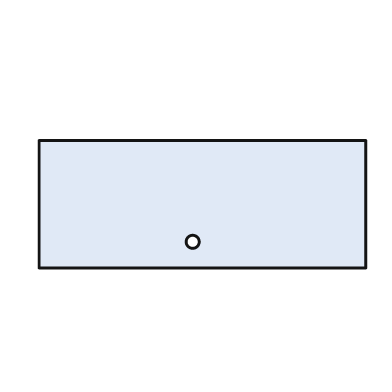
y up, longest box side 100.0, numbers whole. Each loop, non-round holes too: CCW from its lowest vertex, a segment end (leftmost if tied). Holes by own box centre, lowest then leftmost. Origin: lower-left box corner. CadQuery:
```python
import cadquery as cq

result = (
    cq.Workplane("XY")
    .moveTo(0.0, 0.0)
    .lineTo(100.0, 0.0)
    .lineTo(100.0, 39.0)
    .lineTo(0.0, 39.0)
    .close()
    .moveTo(47.0, 8.0)
    .circle(2.0)
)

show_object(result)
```